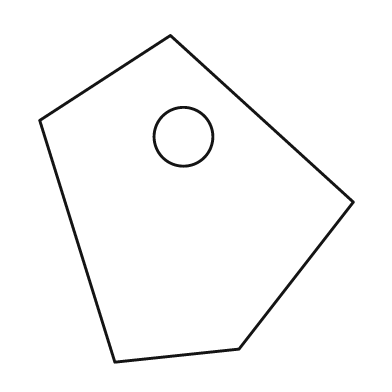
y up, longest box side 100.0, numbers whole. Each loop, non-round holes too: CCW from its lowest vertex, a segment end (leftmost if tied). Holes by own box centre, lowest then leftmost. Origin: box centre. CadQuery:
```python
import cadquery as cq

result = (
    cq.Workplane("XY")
    .moveTo(-25.0, -50.0)
    .lineTo(13.0, -46.0)
    .lineTo(48.0, -1.0)
    .lineTo(-8.0, 50.0)
    .lineTo(-48.0, 24.0)
    .close()
    .moveTo(-4.0, 19.0)
    .circle(9.0)
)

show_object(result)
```